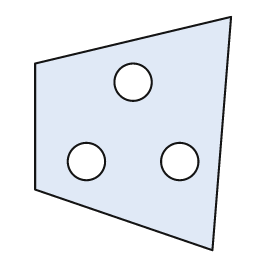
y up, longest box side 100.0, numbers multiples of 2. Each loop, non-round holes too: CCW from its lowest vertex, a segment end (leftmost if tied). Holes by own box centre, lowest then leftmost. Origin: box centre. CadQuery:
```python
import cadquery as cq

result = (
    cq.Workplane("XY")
    .moveTo(34.0, -50.0)
    .lineTo(42.0, 50.0)
    .lineTo(-42.0, 30.0)
    .lineTo(-42.0, -24.0)
    .close()
    .moveTo(-20.0, -12.0)
    .circle(8.0)
    .moveTo(20.0, -12.0)
    .circle(8.0)
    .moveTo(0.0, 22.0)
    .circle(8.0)
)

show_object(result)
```